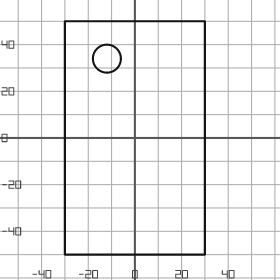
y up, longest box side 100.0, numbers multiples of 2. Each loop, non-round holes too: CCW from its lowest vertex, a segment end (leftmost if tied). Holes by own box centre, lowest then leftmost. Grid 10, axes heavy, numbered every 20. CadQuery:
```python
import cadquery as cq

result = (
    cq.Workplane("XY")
    .moveTo(-30.0, -50.0)
    .lineTo(30.0, -50.0)
    .lineTo(30.0, 50.0)
    .lineTo(-30.0, 50.0)
    .close()
    .moveTo(-12.0, 34.0)
    .circle(6.0)
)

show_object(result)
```